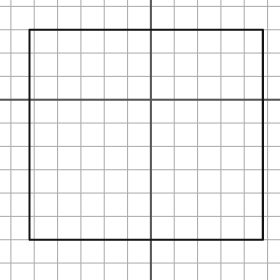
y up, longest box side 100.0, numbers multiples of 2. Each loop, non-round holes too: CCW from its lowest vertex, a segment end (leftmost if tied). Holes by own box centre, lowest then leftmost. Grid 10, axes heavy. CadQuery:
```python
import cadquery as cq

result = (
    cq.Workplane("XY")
    .moveTo(-52.0, -60.0)
    .lineTo(48.0, -60.0)
    .lineTo(48.0, 30.0)
    .lineTo(-52.0, 30.0)
    .close()
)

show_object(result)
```